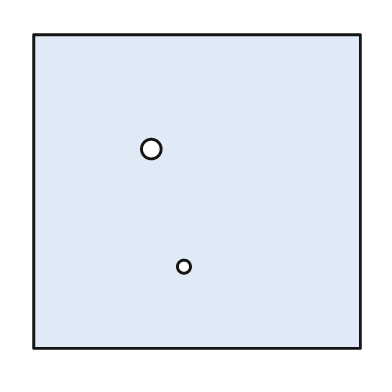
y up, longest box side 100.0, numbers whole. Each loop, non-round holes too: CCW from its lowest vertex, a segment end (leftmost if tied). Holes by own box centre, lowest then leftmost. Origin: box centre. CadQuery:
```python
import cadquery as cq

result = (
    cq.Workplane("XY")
    .moveTo(-50.0, -48.0)
    .lineTo(50.0, -48.0)
    .lineTo(50.0, 48.0)
    .lineTo(-50.0, 48.0)
    .close()
    .moveTo(-4.0, -23.0)
    .circle(2.0)
    .moveTo(-14.0, 13.0)
    .circle(3.0)
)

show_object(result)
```